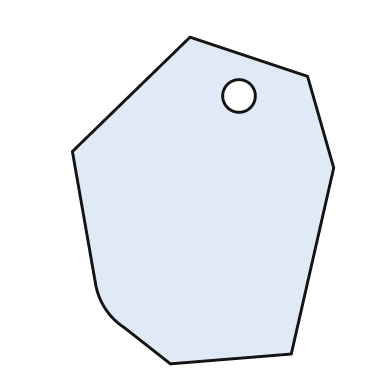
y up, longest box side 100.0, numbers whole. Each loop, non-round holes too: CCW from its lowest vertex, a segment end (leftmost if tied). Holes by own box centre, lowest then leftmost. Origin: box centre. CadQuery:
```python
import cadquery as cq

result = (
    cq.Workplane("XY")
    .moveTo(-10.0, -50.0)
    .lineTo(27.0, -47.0)
    .lineTo(40.0, 10.0)
    .lineTo(32.0, 38.0)
    .lineTo(-4.0, 50.0)
    .lineTo(-40.0, 15.0)
    .lineTo(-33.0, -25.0)
    .threePointArc((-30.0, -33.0), (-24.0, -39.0))
    .close()
    .moveTo(11.0, 32.0)
    .circle(5.0)
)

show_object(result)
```